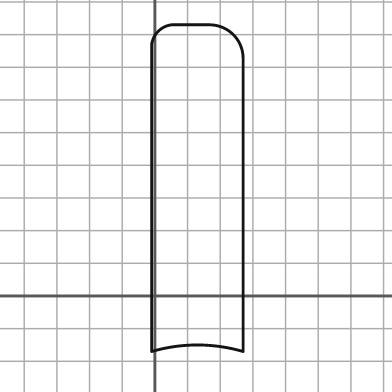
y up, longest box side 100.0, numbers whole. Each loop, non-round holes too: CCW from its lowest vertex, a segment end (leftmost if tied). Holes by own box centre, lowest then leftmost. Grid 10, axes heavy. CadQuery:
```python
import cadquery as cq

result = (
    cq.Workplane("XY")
    .moveTo(-1.0, -17.0)
    .threePointArc((13.0, -15.0), (27.0, -17.0))
    .lineTo(27.0, 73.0)
    .threePointArc((24.0, 80.0), (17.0, 83.0))
    .lineTo(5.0, 83.0)
    .threePointArc((1.0, 81.0), (-1.0, 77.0))
    .close()
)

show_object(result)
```